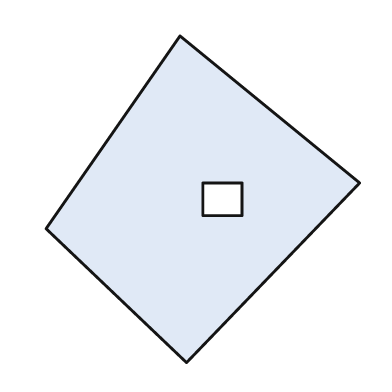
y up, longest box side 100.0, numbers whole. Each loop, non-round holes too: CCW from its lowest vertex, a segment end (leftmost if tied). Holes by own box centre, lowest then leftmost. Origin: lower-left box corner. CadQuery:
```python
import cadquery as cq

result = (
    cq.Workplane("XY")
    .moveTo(43.0, 0.0)
    .lineTo(96.0, 55.0)
    .lineTo(41.0, 100.0)
    .lineTo(0.0, 41.0)
    .close()
    .moveTo(48.0, 45.0)
    .lineTo(60.0, 45.0)
    .lineTo(60.0, 55.0)
    .lineTo(48.0, 55.0)
    .close()
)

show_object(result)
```